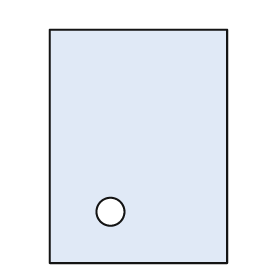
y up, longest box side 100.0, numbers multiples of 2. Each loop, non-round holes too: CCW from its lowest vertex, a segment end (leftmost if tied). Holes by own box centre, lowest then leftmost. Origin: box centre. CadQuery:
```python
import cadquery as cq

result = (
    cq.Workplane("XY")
    .moveTo(-38.0, -50.0)
    .lineTo(38.0, -50.0)
    .lineTo(38.0, 50.0)
    .lineTo(-38.0, 50.0)
    .close()
    .moveTo(-12.0, -28.0)
    .circle(6.0)
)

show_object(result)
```